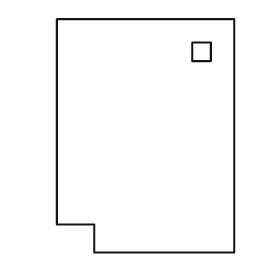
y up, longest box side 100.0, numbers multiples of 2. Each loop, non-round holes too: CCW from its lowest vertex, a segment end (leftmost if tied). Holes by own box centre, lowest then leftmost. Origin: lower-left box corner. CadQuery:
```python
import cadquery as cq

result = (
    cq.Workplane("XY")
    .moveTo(16.0, 0.0)
    .lineTo(76.0, 0.0)
    .lineTo(76.0, 100.0)
    .lineTo(0.0, 100.0)
    .lineTo(0.0, 12.0)
    .lineTo(16.0, 12.0)
    .close()
    .moveTo(58.0, 82.0)
    .lineTo(66.0, 82.0)
    .lineTo(66.0, 90.0)
    .lineTo(58.0, 90.0)
    .close()
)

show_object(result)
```